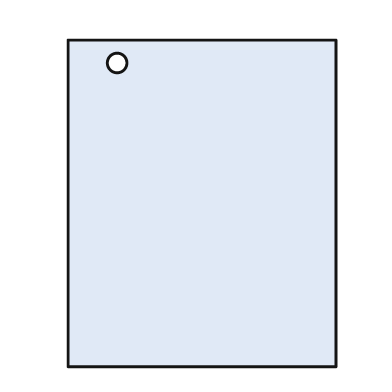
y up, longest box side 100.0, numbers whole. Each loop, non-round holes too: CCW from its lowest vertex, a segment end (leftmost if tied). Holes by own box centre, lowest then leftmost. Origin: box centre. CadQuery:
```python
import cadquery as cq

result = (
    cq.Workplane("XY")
    .moveTo(-41.0, -50.0)
    .lineTo(41.0, -50.0)
    .lineTo(41.0, 50.0)
    .lineTo(-41.0, 50.0)
    .close()
    .moveTo(-26.0, 43.0)
    .circle(3.0)
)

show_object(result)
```